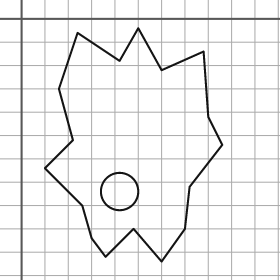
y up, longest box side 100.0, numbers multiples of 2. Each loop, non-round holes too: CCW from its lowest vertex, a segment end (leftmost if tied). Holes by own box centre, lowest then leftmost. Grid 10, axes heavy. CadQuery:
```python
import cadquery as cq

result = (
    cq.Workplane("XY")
    .moveTo(60.0, -104.0)
    .lineTo(70.0, -90.0)
    .lineTo(72.0, -72.0)
    .lineTo(86.0, -54.0)
    .lineTo(80.0, -42.0)
    .lineTo(78.0, -14.0)
    .lineTo(60.0, -22.0)
    .lineTo(50.0, -4.0)
    .lineTo(42.0, -18.0)
    .lineTo(24.0, -6.0)
    .lineTo(16.0, -30.0)
    .lineTo(22.0, -52.0)
    .lineTo(10.0, -64.0)
    .lineTo(26.0, -80.0)
    .lineTo(30.0, -94.0)
    .lineTo(36.0, -102.0)
    .lineTo(48.0, -90.0)
    .close()
    .moveTo(42.0, -74.0)
    .circle(8.0)
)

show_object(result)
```